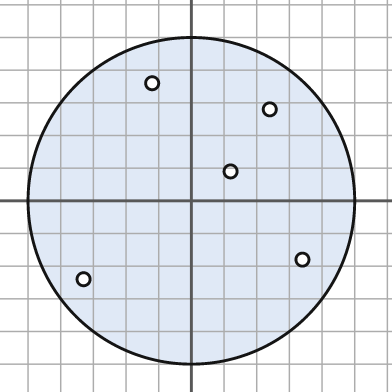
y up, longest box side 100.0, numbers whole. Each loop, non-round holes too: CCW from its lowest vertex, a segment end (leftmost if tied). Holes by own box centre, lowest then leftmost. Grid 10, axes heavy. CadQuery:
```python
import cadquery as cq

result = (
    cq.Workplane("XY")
    .moveTo(0.0, 0.0)
    .circle(50.0)
    .moveTo(-33.0, -24.0)
    .circle(2.0)
    .moveTo(34.0, -18.0)
    .circle(2.0)
    .moveTo(12.0, 9.0)
    .circle(2.0)
    .moveTo(24.0, 28.0)
    .circle(2.0)
    .moveTo(-12.0, 36.0)
    .circle(2.0)
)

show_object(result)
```